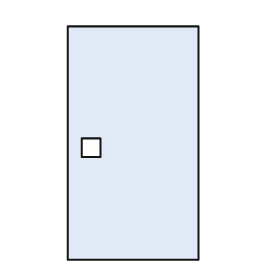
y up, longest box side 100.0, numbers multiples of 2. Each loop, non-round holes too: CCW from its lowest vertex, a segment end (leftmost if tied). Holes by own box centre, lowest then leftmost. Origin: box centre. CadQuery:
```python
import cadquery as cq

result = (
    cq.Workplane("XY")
    .moveTo(-28.0, -50.0)
    .lineTo(28.0, -50.0)
    .lineTo(28.0, 50.0)
    .lineTo(-28.0, 50.0)
    .close()
    .moveTo(-22.0, -6.0)
    .lineTo(-14.0, -6.0)
    .lineTo(-14.0, 2.0)
    .lineTo(-22.0, 2.0)
    .close()
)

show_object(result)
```